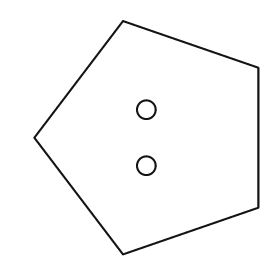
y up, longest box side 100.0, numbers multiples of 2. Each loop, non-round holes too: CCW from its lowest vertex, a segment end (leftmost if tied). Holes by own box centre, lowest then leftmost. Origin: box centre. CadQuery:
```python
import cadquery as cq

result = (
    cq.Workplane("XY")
    .moveTo(-10.0, -50.0)
    .lineTo(48.0, -30.0)
    .lineTo(48.0, 30.0)
    .lineTo(-10.0, 50.0)
    .lineTo(-48.0, 0.0)
    .close()
    .moveTo(0.0, -12.0)
    .circle(4.0)
    .moveTo(0.0, 12.0)
    .circle(4.0)
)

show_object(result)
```